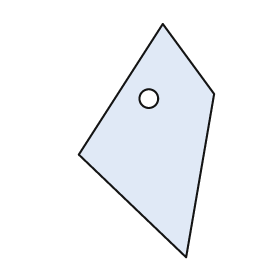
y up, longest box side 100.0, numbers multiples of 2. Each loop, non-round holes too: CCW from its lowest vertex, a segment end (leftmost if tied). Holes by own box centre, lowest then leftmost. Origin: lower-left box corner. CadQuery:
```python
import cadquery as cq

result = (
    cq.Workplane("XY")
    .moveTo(46.0, 0.0)
    .lineTo(58.0, 70.0)
    .lineTo(36.0, 100.0)
    .lineTo(0.0, 44.0)
    .close()
    .moveTo(30.0, 68.0)
    .circle(4.0)
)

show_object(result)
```